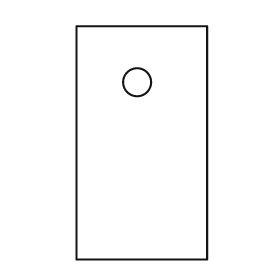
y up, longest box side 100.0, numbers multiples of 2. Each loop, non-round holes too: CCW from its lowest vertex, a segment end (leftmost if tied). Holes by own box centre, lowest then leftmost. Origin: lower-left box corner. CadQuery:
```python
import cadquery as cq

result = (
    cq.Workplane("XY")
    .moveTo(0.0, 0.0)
    .lineTo(56.0, 0.0)
    .lineTo(56.0, 100.0)
    .lineTo(0.0, 100.0)
    .close()
    .moveTo(26.0, 76.0)
    .circle(6.0)
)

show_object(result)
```